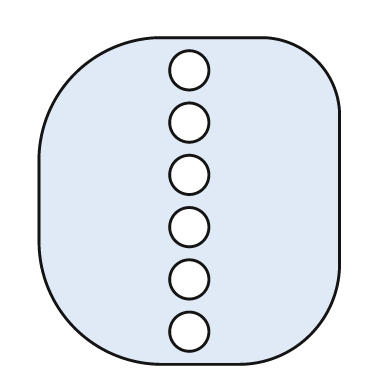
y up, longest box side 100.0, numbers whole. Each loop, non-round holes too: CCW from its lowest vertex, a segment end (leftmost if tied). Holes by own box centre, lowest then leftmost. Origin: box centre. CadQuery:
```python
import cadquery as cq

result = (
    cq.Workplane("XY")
    .moveTo(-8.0, -50.0)
    .lineTo(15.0, -50.0)
    .threePointArc((37.0, -41.0), (46.0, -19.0))
    .lineTo(46.0, 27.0)
    .threePointArc((39.0, 43.0), (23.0, 50.0))
    .lineTo(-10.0, 50.0)
    .threePointArc((-35.0, 39.0), (-46.0, 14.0))
    .lineTo(-46.0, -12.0)
    .threePointArc((-35.0, -39.0), (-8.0, -50.0))
    .close()
    .moveTo(0.0, -40.0)
    .circle(6.0)
    .moveTo(0.0, -24.0)
    .circle(6.0)
    .moveTo(0.0, -8.0)
    .circle(6.0)
    .moveTo(0.0, 8.0)
    .circle(6.0)
    .moveTo(0.0, 24.0)
    .circle(6.0)
    .moveTo(0.0, 40.0)
    .circle(6.0)
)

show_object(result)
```